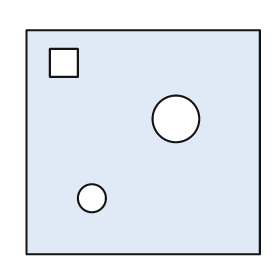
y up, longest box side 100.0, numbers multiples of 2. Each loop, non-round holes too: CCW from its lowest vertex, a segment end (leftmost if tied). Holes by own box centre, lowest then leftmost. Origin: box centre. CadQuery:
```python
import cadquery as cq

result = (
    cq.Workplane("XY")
    .moveTo(-50.0, -48.0)
    .lineTo(50.0, -48.0)
    .lineTo(50.0, 48.0)
    .lineTo(-50.0, 48.0)
    .close()
    .moveTo(-22.0, -24.0)
    .circle(6.0)
    .moveTo(14.0, 10.0)
    .circle(10.0)
    .moveTo(-40.0, 28.0)
    .lineTo(-28.0, 28.0)
    .lineTo(-28.0, 40.0)
    .lineTo(-40.0, 40.0)
    .close()
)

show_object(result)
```